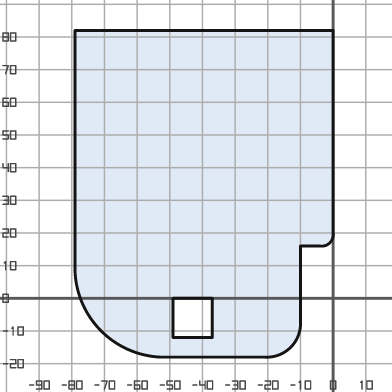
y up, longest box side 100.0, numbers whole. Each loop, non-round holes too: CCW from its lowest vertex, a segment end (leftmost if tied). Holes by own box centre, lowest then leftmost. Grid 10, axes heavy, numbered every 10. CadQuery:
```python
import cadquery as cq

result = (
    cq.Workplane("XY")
    .moveTo(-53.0, -18.0)
    .lineTo(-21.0, -18.0)
    .threePointArc((-13.0, -15.0), (-10.0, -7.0))
    .lineTo(-10.0, 16.0)
    .lineTo(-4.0, 16.0)
    .threePointArc((-1.0, 17.0), (0.0, 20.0))
    .lineTo(0.0, 82.0)
    .lineTo(-79.0, 82.0)
    .lineTo(-79.0, 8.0)
    .threePointArc((-71.0, -10.0), (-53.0, -18.0))
    .close()
    .moveTo(-49.0, -12.0)
    .lineTo(-37.0, -12.0)
    .lineTo(-37.0, 0.0)
    .lineTo(-49.0, 0.0)
    .close()
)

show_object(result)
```